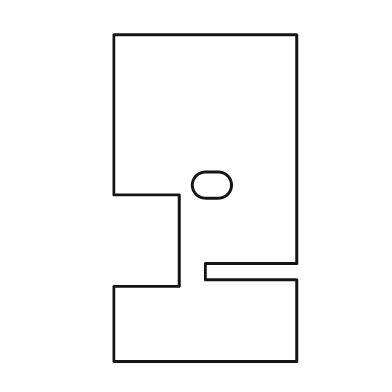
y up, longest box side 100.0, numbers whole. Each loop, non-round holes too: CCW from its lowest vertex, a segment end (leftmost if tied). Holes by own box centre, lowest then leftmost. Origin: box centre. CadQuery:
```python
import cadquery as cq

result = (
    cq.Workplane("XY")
    .moveTo(-28.0, -50.0)
    .lineTo(28.0, -50.0)
    .lineTo(28.0, -25.0)
    .lineTo(0.0, -25.0)
    .lineTo(0.0, -20.0)
    .lineTo(28.0, -20.0)
    .lineTo(28.0, 50.0)
    .lineTo(-28.0, 50.0)
    .lineTo(-28.0, 1.0)
    .lineTo(-8.0, 1.0)
    .lineTo(-8.0, -27.0)
    .lineTo(-28.0, -27.0)
    .close()
    .moveTo(0.0, 0.0)
    .lineTo(4.0, 0.0)
    .threePointArc((8.0, 4.0), (4.0, 8.0))
    .lineTo(0.0, 8.0)
    .threePointArc((-4.0, 4.0), (0.0, 0.0))
    .close()
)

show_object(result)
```